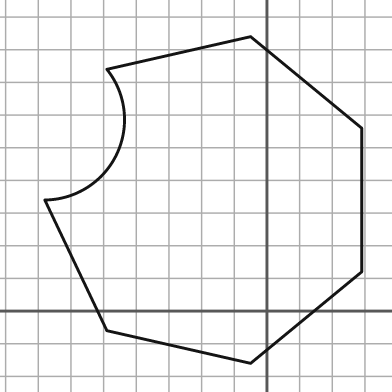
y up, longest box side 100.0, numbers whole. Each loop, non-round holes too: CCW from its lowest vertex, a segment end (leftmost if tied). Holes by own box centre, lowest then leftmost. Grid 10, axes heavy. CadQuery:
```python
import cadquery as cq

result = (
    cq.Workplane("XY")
    .moveTo(-5.0, -16.0)
    .lineTo(29.0, 12.0)
    .lineTo(29.0, 56.0)
    .lineTo(-5.0, 84.0)
    .lineTo(-49.0, 74.0)
    .threePointArc((-46.0, 48.0), (-68.0, 34.0))
    .lineTo(-49.0, -6.0)
    .close()
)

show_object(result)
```